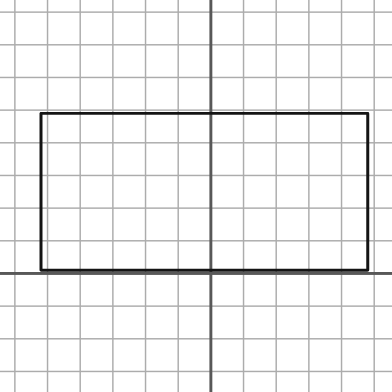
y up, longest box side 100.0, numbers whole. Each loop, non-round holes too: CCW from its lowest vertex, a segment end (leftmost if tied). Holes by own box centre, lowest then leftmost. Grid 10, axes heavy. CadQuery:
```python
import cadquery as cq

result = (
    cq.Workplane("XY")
    .moveTo(-52.0, 1.0)
    .lineTo(48.0, 1.0)
    .lineTo(48.0, 49.0)
    .lineTo(-52.0, 49.0)
    .close()
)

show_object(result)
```